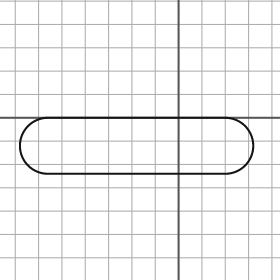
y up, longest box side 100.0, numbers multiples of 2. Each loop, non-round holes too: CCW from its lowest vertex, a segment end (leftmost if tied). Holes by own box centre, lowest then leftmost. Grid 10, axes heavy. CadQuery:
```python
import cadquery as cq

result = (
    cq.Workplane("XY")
    .moveTo(-56.0, -24.0)
    .lineTo(20.0, -24.0)
    .threePointArc((32.0, -12.0), (20.0, 0.0))
    .lineTo(-56.0, 0.0)
    .threePointArc((-68.0, -12.0), (-56.0, -24.0))
    .close()
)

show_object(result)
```